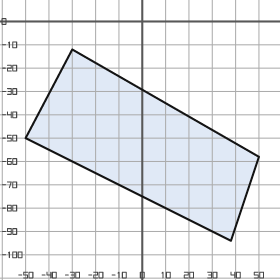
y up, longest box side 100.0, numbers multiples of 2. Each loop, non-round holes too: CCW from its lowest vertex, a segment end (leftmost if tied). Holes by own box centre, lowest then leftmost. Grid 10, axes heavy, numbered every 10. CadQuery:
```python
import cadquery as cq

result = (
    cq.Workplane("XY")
    .moveTo(38.0, -94.0)
    .lineTo(50.0, -58.0)
    .lineTo(-30.0, -12.0)
    .lineTo(-50.0, -50.0)
    .close()
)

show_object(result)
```